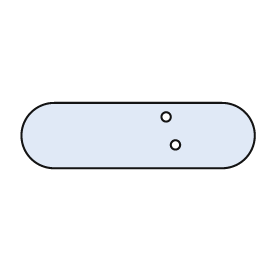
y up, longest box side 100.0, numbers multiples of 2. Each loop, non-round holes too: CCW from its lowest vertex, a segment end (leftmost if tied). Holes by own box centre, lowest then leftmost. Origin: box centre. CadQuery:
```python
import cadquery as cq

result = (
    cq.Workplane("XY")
    .moveTo(-36.0, -14.0)
    .lineTo(36.0, -14.0)
    .threePointArc((50.0, 0.0), (36.0, 14.0))
    .lineTo(-36.0, 14.0)
    .threePointArc((-50.0, 0.0), (-36.0, -14.0))
    .close()
    .moveTo(16.0, -4.0)
    .circle(2.0)
    .moveTo(12.0, 8.0)
    .circle(2.0)
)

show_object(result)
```